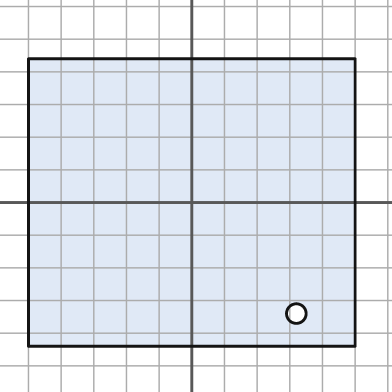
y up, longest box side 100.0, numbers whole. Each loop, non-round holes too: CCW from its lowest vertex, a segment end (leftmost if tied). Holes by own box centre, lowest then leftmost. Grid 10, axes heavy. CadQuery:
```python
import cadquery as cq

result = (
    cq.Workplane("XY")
    .moveTo(-50.0, -44.0)
    .lineTo(50.0, -44.0)
    .lineTo(50.0, 44.0)
    .lineTo(-50.0, 44.0)
    .close()
    .moveTo(32.0, -34.0)
    .circle(3.0)
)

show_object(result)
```